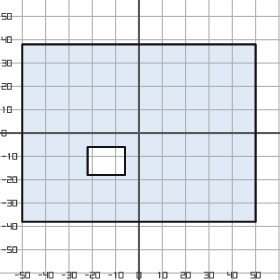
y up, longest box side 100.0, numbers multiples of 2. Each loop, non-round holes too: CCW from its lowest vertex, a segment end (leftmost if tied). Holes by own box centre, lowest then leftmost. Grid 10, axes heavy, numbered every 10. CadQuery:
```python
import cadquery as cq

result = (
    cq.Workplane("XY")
    .moveTo(-50.0, -38.0)
    .lineTo(50.0, -38.0)
    .lineTo(50.0, 38.0)
    .lineTo(-50.0, 38.0)
    .close()
    .moveTo(-22.0, -18.0)
    .lineTo(-6.0, -18.0)
    .lineTo(-6.0, -6.0)
    .lineTo(-22.0, -6.0)
    .close()
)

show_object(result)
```